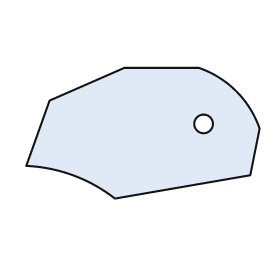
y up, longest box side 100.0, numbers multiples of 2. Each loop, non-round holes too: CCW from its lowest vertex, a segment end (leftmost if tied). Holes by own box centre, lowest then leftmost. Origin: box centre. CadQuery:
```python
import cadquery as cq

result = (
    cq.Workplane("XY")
    .moveTo(-12.0, -28.0)
    .lineTo(46.0, -18.0)
    .lineTo(50.0, 2.0)
    .threePointArc((40.0, 18.0), (24.0, 28.0))
    .lineTo(-8.0, 28.0)
    .lineTo(-40.0, 14.0)
    .lineTo(-50.0, -14.0)
    .threePointArc((-30.0, -18.0), (-12.0, -28.0))
    .close()
    .moveTo(26.0, 4.0)
    .circle(4.0)
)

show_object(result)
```